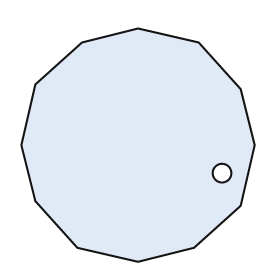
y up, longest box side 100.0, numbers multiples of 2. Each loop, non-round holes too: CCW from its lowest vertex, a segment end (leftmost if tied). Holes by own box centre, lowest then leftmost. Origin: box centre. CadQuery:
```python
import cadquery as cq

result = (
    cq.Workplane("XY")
    .moveTo(0.0, -50.0)
    .lineTo(24.0, -44.0)
    .lineTo(44.0, -26.0)
    .lineTo(50.0, 0.0)
    .lineTo(44.0, 24.0)
    .lineTo(26.0, 44.0)
    .lineTo(0.0, 50.0)
    .lineTo(-24.0, 44.0)
    .lineTo(-44.0, 26.0)
    .lineTo(-50.0, 0.0)
    .lineTo(-44.0, -24.0)
    .lineTo(-26.0, -44.0)
    .close()
    .moveTo(36.0, -12.0)
    .circle(4.0)
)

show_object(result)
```